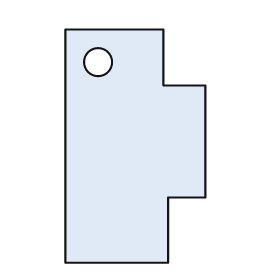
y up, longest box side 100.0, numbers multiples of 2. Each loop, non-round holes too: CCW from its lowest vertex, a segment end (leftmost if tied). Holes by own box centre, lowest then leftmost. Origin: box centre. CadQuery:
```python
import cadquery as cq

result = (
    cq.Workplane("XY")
    .moveTo(-30.0, -50.0)
    .lineTo(14.0, -50.0)
    .lineTo(14.0, -22.0)
    .lineTo(30.0, -22.0)
    .lineTo(30.0, 26.0)
    .lineTo(12.0, 26.0)
    .lineTo(12.0, 50.0)
    .lineTo(-30.0, 50.0)
    .close()
    .moveTo(-16.0, 36.0)
    .circle(6.0)
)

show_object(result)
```